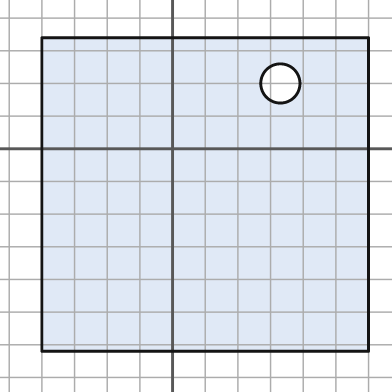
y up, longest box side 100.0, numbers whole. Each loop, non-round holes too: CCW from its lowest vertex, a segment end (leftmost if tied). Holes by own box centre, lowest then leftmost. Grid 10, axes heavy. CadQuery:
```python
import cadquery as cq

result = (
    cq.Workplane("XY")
    .moveTo(-40.0, -62.0)
    .lineTo(60.0, -62.0)
    .lineTo(60.0, 34.0)
    .lineTo(-40.0, 34.0)
    .close()
    .moveTo(33.0, 20.0)
    .circle(6.0)
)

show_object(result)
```